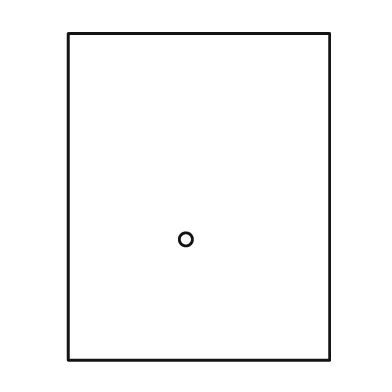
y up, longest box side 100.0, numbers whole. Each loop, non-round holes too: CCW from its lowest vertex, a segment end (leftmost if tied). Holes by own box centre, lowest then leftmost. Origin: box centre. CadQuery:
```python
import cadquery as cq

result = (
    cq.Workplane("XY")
    .moveTo(-40.0, -50.0)
    .lineTo(40.0, -50.0)
    .lineTo(40.0, 50.0)
    .lineTo(-40.0, 50.0)
    .close()
    .moveTo(-4.0, -13.0)
    .circle(2.0)
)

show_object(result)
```